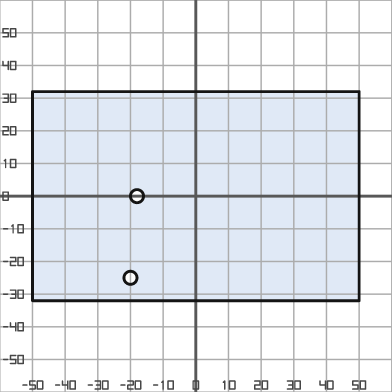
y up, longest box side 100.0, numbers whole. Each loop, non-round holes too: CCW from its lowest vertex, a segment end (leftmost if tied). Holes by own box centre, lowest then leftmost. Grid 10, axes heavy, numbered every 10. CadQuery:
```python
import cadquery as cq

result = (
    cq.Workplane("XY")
    .moveTo(-50.0, -32.0)
    .lineTo(50.0, -32.0)
    .lineTo(50.0, 32.0)
    .lineTo(-50.0, 32.0)
    .close()
    .moveTo(-20.0, -25.0)
    .circle(2.0)
    .moveTo(-18.0, 0.0)
    .circle(2.0)
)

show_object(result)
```